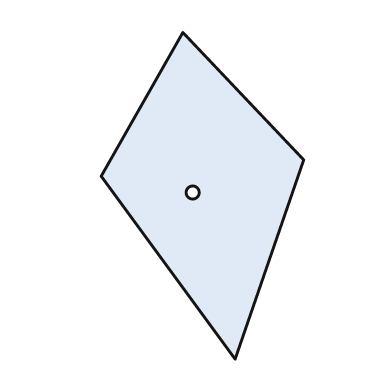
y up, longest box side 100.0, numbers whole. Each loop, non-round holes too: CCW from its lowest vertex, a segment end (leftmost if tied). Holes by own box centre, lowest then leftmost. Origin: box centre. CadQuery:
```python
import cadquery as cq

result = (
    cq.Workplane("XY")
    .moveTo(10.0, -50.0)
    .lineTo(31.0, 11.0)
    .lineTo(-6.0, 50.0)
    .lineTo(-31.0, 6.0)
    .close()
    .moveTo(-3.0, 1.0)
    .circle(2.0)
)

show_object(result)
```